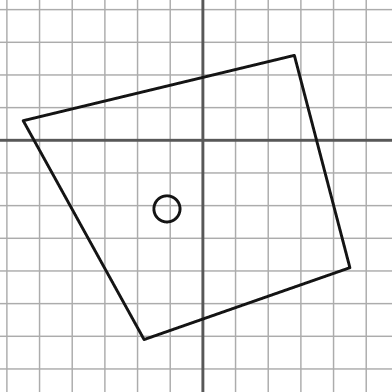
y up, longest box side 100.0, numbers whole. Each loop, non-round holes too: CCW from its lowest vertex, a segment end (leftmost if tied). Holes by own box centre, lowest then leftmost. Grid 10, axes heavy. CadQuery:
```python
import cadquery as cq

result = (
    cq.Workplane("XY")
    .moveTo(-18.0, -61.0)
    .lineTo(45.0, -39.0)
    .lineTo(28.0, 26.0)
    .lineTo(-55.0, 6.0)
    .close()
    .moveTo(-11.0, -21.0)
    .circle(4.0)
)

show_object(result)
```